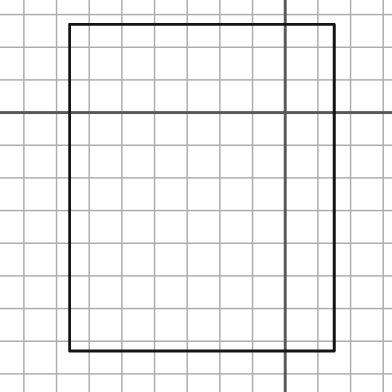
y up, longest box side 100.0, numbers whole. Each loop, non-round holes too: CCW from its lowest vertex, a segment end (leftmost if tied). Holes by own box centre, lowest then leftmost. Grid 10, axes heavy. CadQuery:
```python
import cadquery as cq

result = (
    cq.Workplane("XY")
    .moveTo(-66.0, -73.0)
    .lineTo(15.0, -73.0)
    .lineTo(15.0, 27.0)
    .lineTo(-66.0, 27.0)
    .close()
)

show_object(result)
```